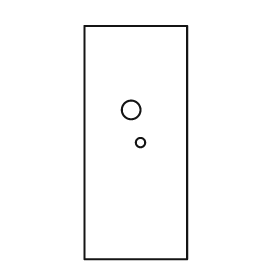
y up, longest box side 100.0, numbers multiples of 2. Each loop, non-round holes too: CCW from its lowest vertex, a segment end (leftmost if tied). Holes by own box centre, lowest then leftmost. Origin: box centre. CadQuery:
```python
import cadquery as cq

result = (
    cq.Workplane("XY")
    .moveTo(-22.0, -50.0)
    .lineTo(22.0, -50.0)
    .lineTo(22.0, 50.0)
    .lineTo(-22.0, 50.0)
    .close()
    .moveTo(2.0, 0.0)
    .circle(2.0)
    .moveTo(-2.0, 14.0)
    .circle(4.0)
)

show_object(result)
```